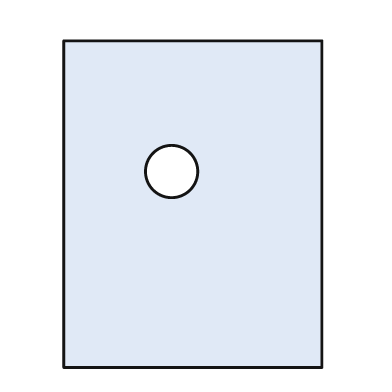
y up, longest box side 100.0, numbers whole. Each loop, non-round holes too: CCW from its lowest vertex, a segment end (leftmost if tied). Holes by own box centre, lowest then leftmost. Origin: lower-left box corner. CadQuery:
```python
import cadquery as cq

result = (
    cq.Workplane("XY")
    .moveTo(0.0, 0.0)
    .lineTo(79.0, 0.0)
    .lineTo(79.0, 100.0)
    .lineTo(0.0, 100.0)
    .close()
    .moveTo(33.0, 60.0)
    .circle(8.0)
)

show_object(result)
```